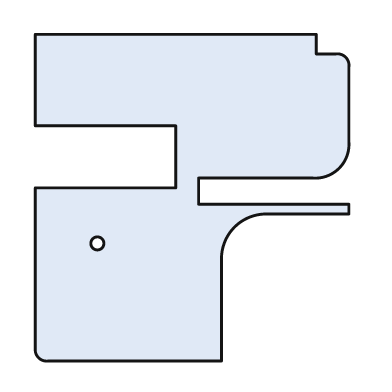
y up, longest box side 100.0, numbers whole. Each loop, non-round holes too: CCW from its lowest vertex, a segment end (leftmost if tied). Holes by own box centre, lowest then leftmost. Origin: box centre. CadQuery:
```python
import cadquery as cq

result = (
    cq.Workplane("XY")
    .moveTo(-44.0, -50.0)
    .lineTo(9.0, -50.0)
    .lineTo(9.0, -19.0)
    .threePointArc((13.0, -9.0), (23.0, -5.0))
    .lineTo(48.0, -5.0)
    .lineTo(48.0, -2.0)
    .lineTo(2.0, -2.0)
    .lineTo(2.0, 6.0)
    .lineTo(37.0, 6.0)
    .threePointArc((45.0, 9.0), (48.0, 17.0))
    .lineTo(48.0, 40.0)
    .threePointArc((47.0, 43.0), (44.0, 44.0))
    .lineTo(38.0, 44.0)
    .lineTo(38.0, 50.0)
    .lineTo(-48.0, 50.0)
    .lineTo(-48.0, 22.0)
    .lineTo(-5.0, 22.0)
    .lineTo(-5.0, 3.0)
    .lineTo(-48.0, 3.0)
    .lineTo(-48.0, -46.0)
    .threePointArc((-47.0, -49.0), (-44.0, -50.0))
    .close()
    .moveTo(-29.0, -14.0)
    .circle(2.0)
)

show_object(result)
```